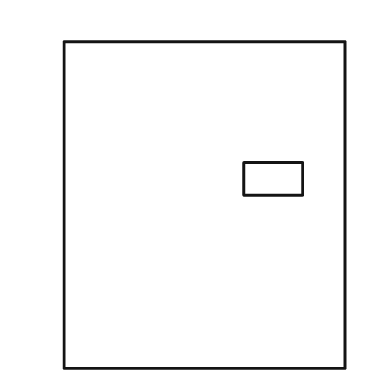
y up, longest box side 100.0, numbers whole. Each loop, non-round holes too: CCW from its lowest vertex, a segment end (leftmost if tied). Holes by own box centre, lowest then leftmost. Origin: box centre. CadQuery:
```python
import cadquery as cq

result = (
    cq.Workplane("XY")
    .moveTo(-43.0, -50.0)
    .lineTo(43.0, -50.0)
    .lineTo(43.0, 50.0)
    .lineTo(-43.0, 50.0)
    .close()
    .moveTo(12.0, 3.0)
    .lineTo(30.0, 3.0)
    .lineTo(30.0, 13.0)
    .lineTo(12.0, 13.0)
    .close()
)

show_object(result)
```